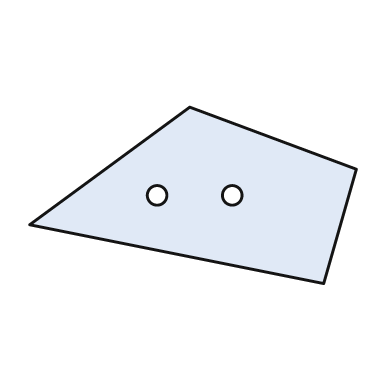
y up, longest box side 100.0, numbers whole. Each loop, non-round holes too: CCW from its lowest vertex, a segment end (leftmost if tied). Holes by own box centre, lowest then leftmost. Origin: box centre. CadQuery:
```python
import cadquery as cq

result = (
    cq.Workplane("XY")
    .moveTo(40.0, -27.0)
    .lineTo(50.0, 8.0)
    .lineTo(-1.0, 27.0)
    .lineTo(-50.0, -9.0)
    .close()
    .moveTo(-11.0, 0.0)
    .circle(3.0)
    .moveTo(12.0, 0.0)
    .circle(3.0)
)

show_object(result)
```